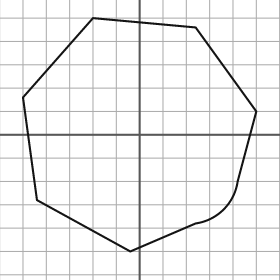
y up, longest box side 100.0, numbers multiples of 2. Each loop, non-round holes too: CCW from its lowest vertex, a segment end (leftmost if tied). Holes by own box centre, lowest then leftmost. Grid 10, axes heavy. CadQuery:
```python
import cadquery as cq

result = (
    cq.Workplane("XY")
    .moveTo(-4.0, -50.0)
    .lineTo(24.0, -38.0)
    .threePointArc((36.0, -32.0), (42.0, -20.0))
    .lineTo(50.0, 10.0)
    .lineTo(24.0, 46.0)
    .lineTo(-20.0, 50.0)
    .lineTo(-50.0, 16.0)
    .lineTo(-44.0, -28.0)
    .close()
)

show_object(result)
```